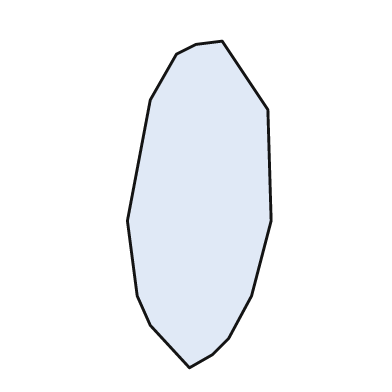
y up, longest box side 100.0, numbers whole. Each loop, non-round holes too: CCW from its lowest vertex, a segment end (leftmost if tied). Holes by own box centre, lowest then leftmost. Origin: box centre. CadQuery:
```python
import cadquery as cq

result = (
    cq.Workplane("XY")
    .moveTo(-3.0, -50.0)
    .lineTo(4.0, -46.0)
    .lineTo(9.0, -41.0)
    .lineTo(16.0, -28.0)
    .lineTo(22.0, -5.0)
    .lineTo(21.0, 29.0)
    .lineTo(7.0, 50.0)
    .lineTo(-1.0, 49.0)
    .lineTo(-7.0, 46.0)
    .lineTo(-15.0, 32.0)
    .lineTo(-22.0, -5.0)
    .lineTo(-19.0, -28.0)
    .lineTo(-15.0, -37.0)
    .close()
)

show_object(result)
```